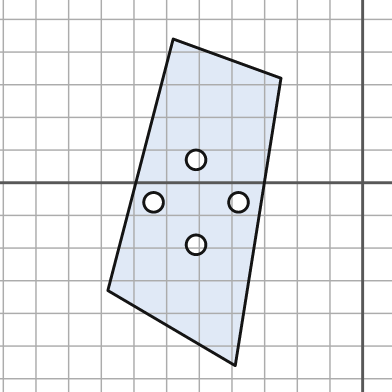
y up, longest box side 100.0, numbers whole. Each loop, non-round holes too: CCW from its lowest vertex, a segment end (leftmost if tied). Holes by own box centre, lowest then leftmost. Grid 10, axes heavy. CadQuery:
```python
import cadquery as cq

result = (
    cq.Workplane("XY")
    .moveTo(-39.0, -56.0)
    .lineTo(-25.0, 32.0)
    .lineTo(-58.0, 44.0)
    .lineTo(-78.0, -33.0)
    .close()
    .moveTo(-51.0, -19.0)
    .circle(3.0)
    .moveTo(-64.0, -6.0)
    .circle(3.0)
    .moveTo(-38.0, -6.0)
    .circle(3.0)
    .moveTo(-51.0, 7.0)
    .circle(3.0)
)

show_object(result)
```